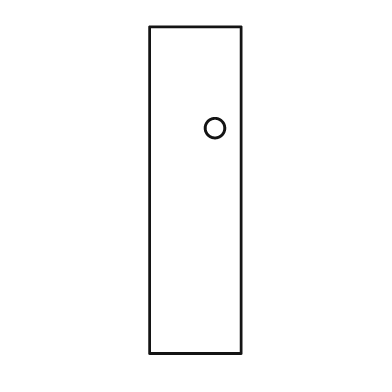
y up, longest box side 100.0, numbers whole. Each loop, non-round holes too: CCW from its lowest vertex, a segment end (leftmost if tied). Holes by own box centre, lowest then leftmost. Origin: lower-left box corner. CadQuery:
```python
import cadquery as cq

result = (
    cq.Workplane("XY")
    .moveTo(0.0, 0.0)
    .lineTo(28.0, 0.0)
    .lineTo(28.0, 100.0)
    .lineTo(0.0, 100.0)
    .close()
    .moveTo(20.0, 69.0)
    .circle(3.0)
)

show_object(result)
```